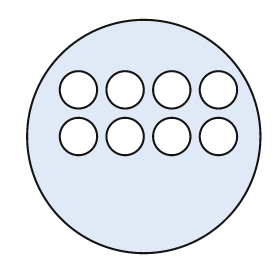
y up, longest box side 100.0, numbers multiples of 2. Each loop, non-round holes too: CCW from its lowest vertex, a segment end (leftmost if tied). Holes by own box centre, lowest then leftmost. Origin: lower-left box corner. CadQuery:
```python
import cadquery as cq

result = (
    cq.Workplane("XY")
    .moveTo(50.0, 50.0)
    .circle(50.0)
    .moveTo(22.0, 50.0)
    .circle(8.0)
    .moveTo(42.0, 50.0)
    .circle(8.0)
    .moveTo(62.0, 50.0)
    .circle(8.0)
    .moveTo(82.0, 50.0)
    .circle(8.0)
    .moveTo(22.0, 70.0)
    .circle(8.0)
    .moveTo(42.0, 70.0)
    .circle(8.0)
    .moveTo(62.0, 70.0)
    .circle(8.0)
    .moveTo(82.0, 70.0)
    .circle(8.0)
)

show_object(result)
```